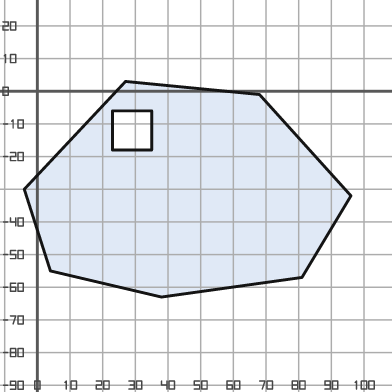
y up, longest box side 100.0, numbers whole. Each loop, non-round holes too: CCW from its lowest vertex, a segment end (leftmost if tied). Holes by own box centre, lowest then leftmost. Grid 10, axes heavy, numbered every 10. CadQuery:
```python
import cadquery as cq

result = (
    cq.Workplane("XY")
    .moveTo(38.0, -63.0)
    .lineTo(81.0, -57.0)
    .lineTo(96.0, -32.0)
    .lineTo(68.0, -1.0)
    .lineTo(27.0, 3.0)
    .lineTo(-4.0, -30.0)
    .lineTo(4.0, -55.0)
    .close()
    .moveTo(23.0, -18.0)
    .lineTo(35.0, -18.0)
    .lineTo(35.0, -6.0)
    .lineTo(23.0, -6.0)
    .close()
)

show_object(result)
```